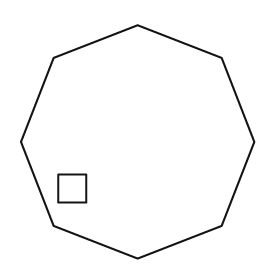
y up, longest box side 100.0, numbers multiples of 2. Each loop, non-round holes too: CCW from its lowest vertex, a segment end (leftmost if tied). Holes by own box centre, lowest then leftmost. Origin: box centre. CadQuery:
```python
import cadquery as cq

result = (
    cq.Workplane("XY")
    .moveTo(0.0, -50.0)
    .lineTo(36.0, -36.0)
    .lineTo(50.0, 0.0)
    .lineTo(36.0, 36.0)
    .lineTo(0.0, 50.0)
    .lineTo(-36.0, 36.0)
    .lineTo(-50.0, 0.0)
    .lineTo(-36.0, -36.0)
    .close()
    .moveTo(-34.0, -26.0)
    .lineTo(-22.0, -26.0)
    .lineTo(-22.0, -14.0)
    .lineTo(-34.0, -14.0)
    .close()
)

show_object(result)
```